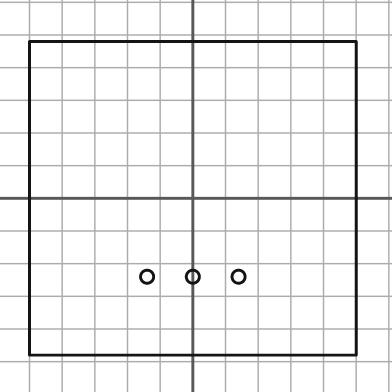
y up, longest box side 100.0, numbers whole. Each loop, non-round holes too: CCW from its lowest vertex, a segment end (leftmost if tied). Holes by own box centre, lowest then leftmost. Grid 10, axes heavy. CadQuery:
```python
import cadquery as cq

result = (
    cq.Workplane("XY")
    .moveTo(-50.0, -48.0)
    .lineTo(50.0, -48.0)
    .lineTo(50.0, 48.0)
    .lineTo(-50.0, 48.0)
    .close()
    .moveTo(-14.0, -24.0)
    .circle(2.0)
    .moveTo(0.0, -24.0)
    .circle(2.0)
    .moveTo(14.0, -24.0)
    .circle(2.0)
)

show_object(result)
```